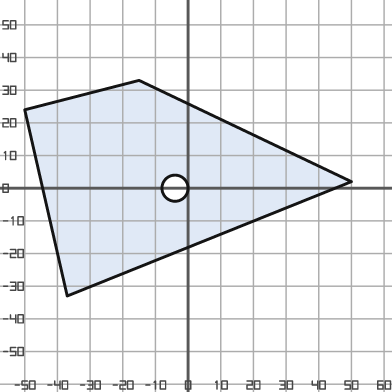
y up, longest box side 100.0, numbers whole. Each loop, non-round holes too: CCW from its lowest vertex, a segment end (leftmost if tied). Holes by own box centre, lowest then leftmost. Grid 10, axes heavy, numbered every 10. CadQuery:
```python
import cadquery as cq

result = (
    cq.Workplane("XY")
    .moveTo(-37.0, -33.0)
    .lineTo(50.0, 2.0)
    .lineTo(-15.0, 33.0)
    .lineTo(-50.0, 24.0)
    .close()
    .moveTo(-4.0, 0.0)
    .circle(4.0)
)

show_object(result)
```